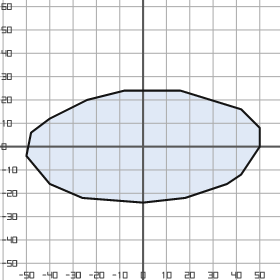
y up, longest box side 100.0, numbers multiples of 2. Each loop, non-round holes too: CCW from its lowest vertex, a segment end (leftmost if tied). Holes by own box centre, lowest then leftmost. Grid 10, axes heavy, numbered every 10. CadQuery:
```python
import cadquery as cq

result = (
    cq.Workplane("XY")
    .moveTo(0.0, -24.0)
    .lineTo(18.0, -22.0)
    .lineTo(36.0, -16.0)
    .lineTo(42.0, -12.0)
    .lineTo(50.0, 0.0)
    .lineTo(50.0, 8.0)
    .lineTo(42.0, 16.0)
    .lineTo(16.0, 24.0)
    .lineTo(-8.0, 24.0)
    .lineTo(-24.0, 20.0)
    .lineTo(-40.0, 12.0)
    .lineTo(-48.0, 6.0)
    .lineTo(-50.0, -4.0)
    .lineTo(-40.0, -16.0)
    .lineTo(-26.0, -22.0)
    .close()
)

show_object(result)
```